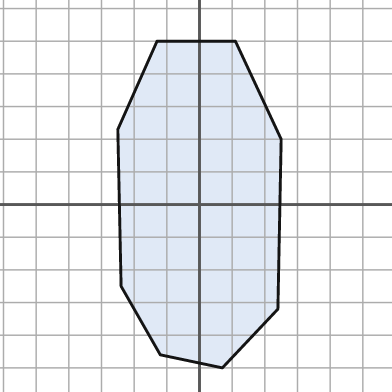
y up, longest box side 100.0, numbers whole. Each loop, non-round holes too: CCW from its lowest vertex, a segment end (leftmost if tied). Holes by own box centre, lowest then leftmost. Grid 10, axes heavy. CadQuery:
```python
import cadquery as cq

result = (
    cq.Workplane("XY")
    .moveTo(7.0, -50.0)
    .lineTo(24.0, -32.0)
    .lineTo(25.0, 20.0)
    .lineTo(11.0, 50.0)
    .lineTo(-13.0, 50.0)
    .lineTo(-25.0, 23.0)
    .lineTo(-24.0, -25.0)
    .lineTo(-12.0, -46.0)
    .close()
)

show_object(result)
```